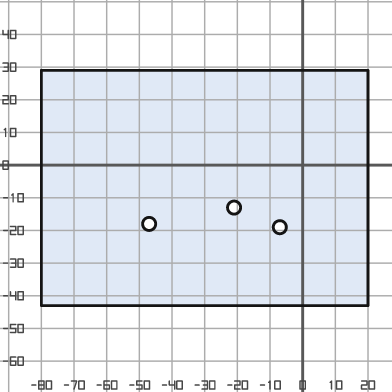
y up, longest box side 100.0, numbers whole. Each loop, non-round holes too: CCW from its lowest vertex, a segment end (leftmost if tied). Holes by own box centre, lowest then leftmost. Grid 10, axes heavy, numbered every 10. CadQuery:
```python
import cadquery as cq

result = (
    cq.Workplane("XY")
    .moveTo(-80.0, -43.0)
    .lineTo(20.0, -43.0)
    .lineTo(20.0, 29.0)
    .lineTo(-80.0, 29.0)
    .close()
    .moveTo(-7.0, -19.0)
    .circle(2.0)
    .moveTo(-47.0, -18.0)
    .circle(2.0)
    .moveTo(-21.0, -13.0)
    .circle(2.0)
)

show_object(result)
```